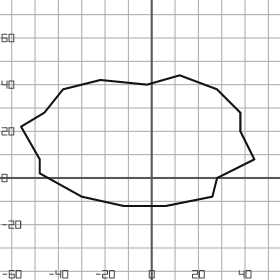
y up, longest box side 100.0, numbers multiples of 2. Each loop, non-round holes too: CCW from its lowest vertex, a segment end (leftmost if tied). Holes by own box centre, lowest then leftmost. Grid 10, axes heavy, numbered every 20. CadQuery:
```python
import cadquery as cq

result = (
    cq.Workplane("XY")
    .moveTo(-12.0, -12.0)
    .lineTo(6.0, -12.0)
    .lineTo(26.0, -8.0)
    .lineTo(28.0, 0.0)
    .lineTo(44.0, 8.0)
    .lineTo(38.0, 20.0)
    .lineTo(38.0, 28.0)
    .lineTo(28.0, 38.0)
    .lineTo(12.0, 44.0)
    .lineTo(-2.0, 40.0)
    .lineTo(-22.0, 42.0)
    .lineTo(-38.0, 38.0)
    .lineTo(-46.0, 28.0)
    .lineTo(-56.0, 22.0)
    .lineTo(-48.0, 8.0)
    .lineTo(-48.0, 2.0)
    .lineTo(-30.0, -8.0)
    .close()
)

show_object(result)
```